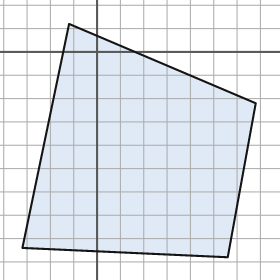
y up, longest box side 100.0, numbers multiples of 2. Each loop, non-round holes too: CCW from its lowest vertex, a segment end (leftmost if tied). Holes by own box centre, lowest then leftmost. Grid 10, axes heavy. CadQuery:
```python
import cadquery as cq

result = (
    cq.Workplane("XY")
    .moveTo(56.0, -88.0)
    .lineTo(68.0, -22.0)
    .lineTo(-12.0, 12.0)
    .lineTo(-32.0, -84.0)
    .close()
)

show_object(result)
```